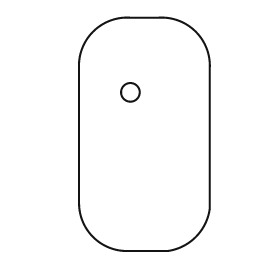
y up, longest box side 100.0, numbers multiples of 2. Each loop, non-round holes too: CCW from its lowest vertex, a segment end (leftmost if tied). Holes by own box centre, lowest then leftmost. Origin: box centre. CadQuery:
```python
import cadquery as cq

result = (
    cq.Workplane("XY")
    .moveTo(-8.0, -50.0)
    .lineTo(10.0, -50.0)
    .threePointArc((22.0, -44.0), (28.0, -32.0))
    .lineTo(28.0, 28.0)
    .threePointArc((22.0, 44.0), (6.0, 50.0))
    .lineTo(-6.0, 50.0)
    .threePointArc((-22.0, 44.0), (-28.0, 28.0))
    .lineTo(-28.0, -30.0)
    .threePointArc((-22.0, -44.0), (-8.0, -50.0))
    .close()
    .moveTo(-6.0, 18.0)
    .circle(4.0)
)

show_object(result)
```